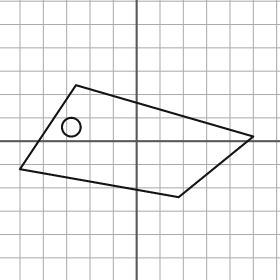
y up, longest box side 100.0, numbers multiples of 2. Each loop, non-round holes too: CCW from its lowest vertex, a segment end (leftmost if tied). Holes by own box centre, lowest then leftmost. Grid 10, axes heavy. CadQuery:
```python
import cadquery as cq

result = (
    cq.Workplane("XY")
    .moveTo(18.0, -24.0)
    .lineTo(50.0, 2.0)
    .lineTo(-26.0, 24.0)
    .lineTo(-50.0, -12.0)
    .close()
    .moveTo(-28.0, 6.0)
    .circle(4.0)
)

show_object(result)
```